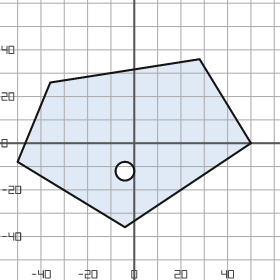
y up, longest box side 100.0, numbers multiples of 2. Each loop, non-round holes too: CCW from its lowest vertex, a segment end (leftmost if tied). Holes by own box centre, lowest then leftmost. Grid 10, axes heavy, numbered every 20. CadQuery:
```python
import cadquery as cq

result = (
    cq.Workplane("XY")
    .moveTo(-4.0, -36.0)
    .lineTo(50.0, 0.0)
    .lineTo(28.0, 36.0)
    .lineTo(-36.0, 26.0)
    .lineTo(-50.0, -8.0)
    .close()
    .moveTo(-4.0, -12.0)
    .circle(4.0)
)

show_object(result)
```